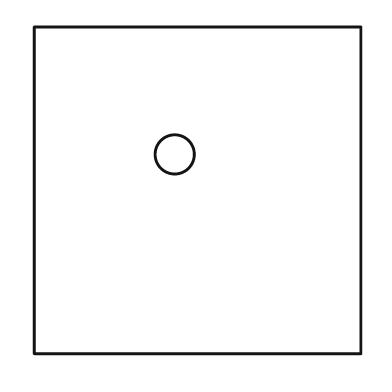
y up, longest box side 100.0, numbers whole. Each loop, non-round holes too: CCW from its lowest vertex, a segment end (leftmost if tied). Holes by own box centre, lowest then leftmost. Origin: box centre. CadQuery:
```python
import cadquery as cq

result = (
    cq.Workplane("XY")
    .moveTo(-50.0, -50.0)
    .lineTo(50.0, -50.0)
    .lineTo(50.0, 50.0)
    .lineTo(-50.0, 50.0)
    .close()
    .moveTo(-7.0, 11.0)
    .circle(6.0)
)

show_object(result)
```